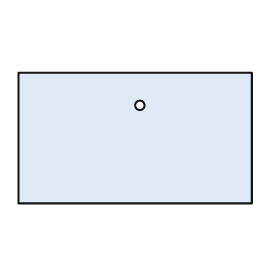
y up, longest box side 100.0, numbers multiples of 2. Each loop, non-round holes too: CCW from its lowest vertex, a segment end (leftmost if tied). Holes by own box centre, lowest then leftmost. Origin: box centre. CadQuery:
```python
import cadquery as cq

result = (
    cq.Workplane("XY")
    .moveTo(-50.0, -28.0)
    .lineTo(50.0, -28.0)
    .lineTo(50.0, 28.0)
    .lineTo(-50.0, 28.0)
    .close()
    .moveTo(2.0, 14.0)
    .circle(2.0)
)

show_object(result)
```